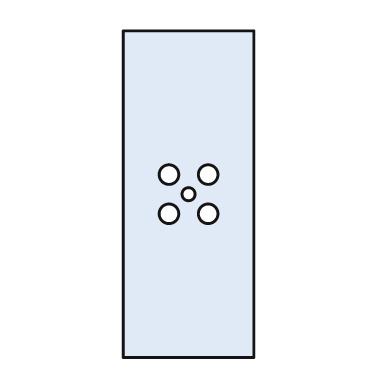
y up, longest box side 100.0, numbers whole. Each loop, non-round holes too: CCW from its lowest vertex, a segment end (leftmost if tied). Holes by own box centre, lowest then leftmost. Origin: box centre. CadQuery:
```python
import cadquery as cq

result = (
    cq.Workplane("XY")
    .moveTo(-20.0, -50.0)
    .lineTo(20.0, -50.0)
    .lineTo(20.0, 50.0)
    .lineTo(-20.0, 50.0)
    .close()
    .moveTo(-6.0, -6.0)
    .circle(3.0)
    .moveTo(6.0, -6.0)
    .circle(3.0)
    .moveTo(0.0, 0.0)
    .circle(2.0)
    .moveTo(-6.0, 6.0)
    .circle(3.0)
    .moveTo(6.0, 6.0)
    .circle(3.0)
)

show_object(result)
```